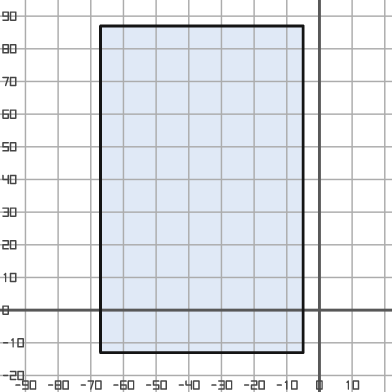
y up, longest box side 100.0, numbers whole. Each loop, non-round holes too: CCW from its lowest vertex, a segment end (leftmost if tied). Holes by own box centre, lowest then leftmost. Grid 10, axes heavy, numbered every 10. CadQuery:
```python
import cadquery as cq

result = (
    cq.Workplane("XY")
    .moveTo(-67.0, -13.0)
    .lineTo(-5.0, -13.0)
    .lineTo(-5.0, 87.0)
    .lineTo(-67.0, 87.0)
    .close()
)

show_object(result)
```